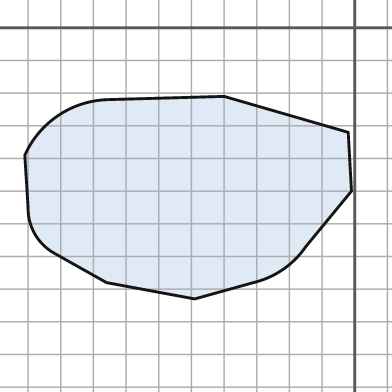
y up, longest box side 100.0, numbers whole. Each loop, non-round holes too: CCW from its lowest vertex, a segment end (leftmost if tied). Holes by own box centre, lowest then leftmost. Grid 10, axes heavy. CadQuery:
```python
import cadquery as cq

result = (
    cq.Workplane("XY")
    .moveTo(-49.0, -83.0)
    .lineTo(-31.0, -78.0)
    .threePointArc((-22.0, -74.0), (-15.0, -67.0))
    .lineTo(-1.0, -50.0)
    .lineTo(-2.0, -32.0)
    .lineTo(-40.0, -21.0)
    .lineTo(-76.0, -22.0)
    .threePointArc((-91.0, -27.0), (-101.0, -39.0))
    .lineTo(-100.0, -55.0)
    .threePointArc((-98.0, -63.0), (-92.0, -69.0))
    .lineTo(-76.0, -78.0)
    .close()
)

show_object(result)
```